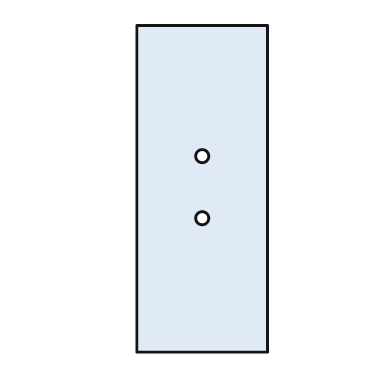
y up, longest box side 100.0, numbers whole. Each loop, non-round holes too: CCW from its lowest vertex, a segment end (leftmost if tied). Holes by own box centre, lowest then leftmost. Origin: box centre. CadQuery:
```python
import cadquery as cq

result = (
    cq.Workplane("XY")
    .moveTo(-20.0, -50.0)
    .lineTo(20.0, -50.0)
    .lineTo(20.0, 50.0)
    .lineTo(-20.0, 50.0)
    .close()
    .moveTo(0.0, -9.0)
    .circle(2.0)
    .moveTo(0.0, 10.0)
    .circle(2.0)
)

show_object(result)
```